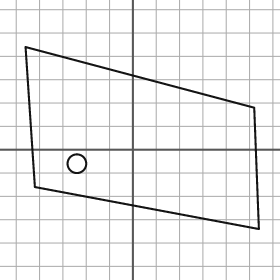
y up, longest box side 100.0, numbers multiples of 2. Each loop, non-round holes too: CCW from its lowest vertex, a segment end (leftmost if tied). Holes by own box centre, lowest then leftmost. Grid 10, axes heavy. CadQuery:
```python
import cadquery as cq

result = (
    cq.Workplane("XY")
    .moveTo(54.0, -34.0)
    .lineTo(52.0, 18.0)
    .lineTo(-46.0, 44.0)
    .lineTo(-42.0, -16.0)
    .close()
    .moveTo(-24.0, -6.0)
    .circle(4.0)
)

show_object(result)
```